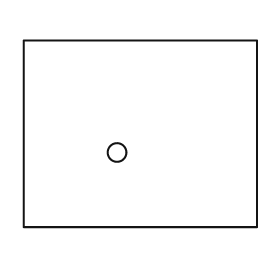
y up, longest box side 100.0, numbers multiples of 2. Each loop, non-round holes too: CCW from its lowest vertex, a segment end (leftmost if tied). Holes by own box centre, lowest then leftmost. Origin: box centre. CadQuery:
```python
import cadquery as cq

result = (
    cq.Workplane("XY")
    .moveTo(-50.0, -40.0)
    .lineTo(50.0, -40.0)
    .lineTo(50.0, 40.0)
    .lineTo(-50.0, 40.0)
    .close()
    .moveTo(-10.0, -8.0)
    .circle(4.0)
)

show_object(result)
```